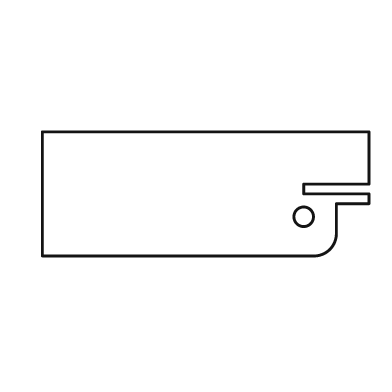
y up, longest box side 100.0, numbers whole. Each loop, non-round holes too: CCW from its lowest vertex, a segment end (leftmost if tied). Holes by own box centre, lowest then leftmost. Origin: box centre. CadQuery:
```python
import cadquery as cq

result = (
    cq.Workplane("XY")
    .moveTo(-50.0, -19.0)
    .lineTo(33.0, -19.0)
    .threePointArc((38.0, -17.0), (40.0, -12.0))
    .lineTo(40.0, -3.0)
    .lineTo(50.0, -3.0)
    .lineTo(50.0, 0.0)
    .lineTo(30.0, 0.0)
    .lineTo(30.0, 3.0)
    .lineTo(50.0, 3.0)
    .lineTo(50.0, 19.0)
    .lineTo(-50.0, 19.0)
    .close()
    .moveTo(30.0, -7.0)
    .circle(3.0)
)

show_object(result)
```